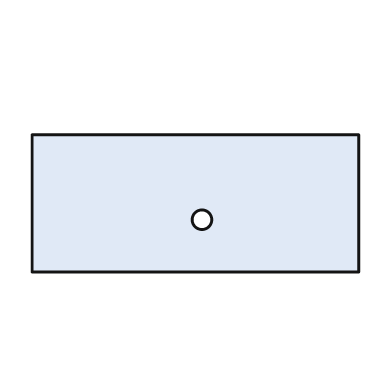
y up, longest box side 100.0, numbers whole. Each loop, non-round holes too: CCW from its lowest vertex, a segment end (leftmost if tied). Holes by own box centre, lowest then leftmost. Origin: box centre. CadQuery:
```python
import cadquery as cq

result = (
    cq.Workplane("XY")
    .moveTo(-50.0, -21.0)
    .lineTo(50.0, -21.0)
    .lineTo(50.0, 21.0)
    .lineTo(-50.0, 21.0)
    .close()
    .moveTo(2.0, -5.0)
    .circle(3.0)
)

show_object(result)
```